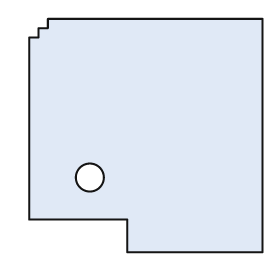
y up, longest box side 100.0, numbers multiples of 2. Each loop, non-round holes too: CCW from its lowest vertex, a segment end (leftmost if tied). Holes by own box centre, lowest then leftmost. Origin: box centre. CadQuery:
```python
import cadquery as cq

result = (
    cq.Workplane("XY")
    .moveTo(-8.0, -50.0)
    .lineTo(50.0, -50.0)
    .lineTo(50.0, 50.0)
    .lineTo(-42.0, 50.0)
    .lineTo(-42.0, 46.0)
    .lineTo(-46.0, 46.0)
    .lineTo(-46.0, 42.0)
    .lineTo(-50.0, 42.0)
    .lineTo(-50.0, -36.0)
    .lineTo(-8.0, -36.0)
    .close()
    .moveTo(-24.0, -18.0)
    .circle(6.0)
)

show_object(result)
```